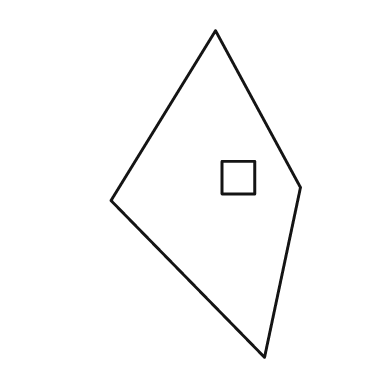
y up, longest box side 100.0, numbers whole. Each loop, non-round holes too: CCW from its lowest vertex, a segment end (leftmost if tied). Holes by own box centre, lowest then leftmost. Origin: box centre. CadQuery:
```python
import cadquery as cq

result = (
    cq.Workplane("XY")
    .moveTo(18.0, -50.0)
    .lineTo(29.0, 2.0)
    .lineTo(3.0, 50.0)
    .lineTo(-29.0, -2.0)
    .close()
    .moveTo(5.0, 0.0)
    .lineTo(15.0, 0.0)
    .lineTo(15.0, 10.0)
    .lineTo(5.0, 10.0)
    .close()
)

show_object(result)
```